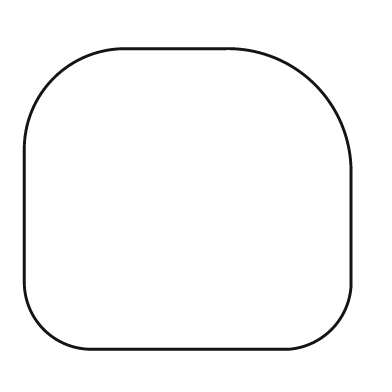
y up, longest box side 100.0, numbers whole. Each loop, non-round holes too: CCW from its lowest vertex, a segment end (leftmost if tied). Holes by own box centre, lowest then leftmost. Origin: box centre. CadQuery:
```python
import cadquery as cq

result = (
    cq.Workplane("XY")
    .moveTo(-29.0, -46.0)
    .lineTo(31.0, -46.0)
    .threePointArc((44.0, -40.0), (50.0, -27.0))
    .lineTo(50.0, 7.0)
    .threePointArc((39.0, 35.0), (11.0, 46.0))
    .lineTo(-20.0, 46.0)
    .threePointArc((-41.0, 37.0), (-50.0, 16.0))
    .lineTo(-50.0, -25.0)
    .threePointArc((-44.0, -40.0), (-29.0, -46.0))
    .close()
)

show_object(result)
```